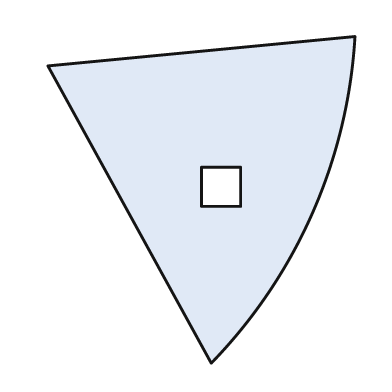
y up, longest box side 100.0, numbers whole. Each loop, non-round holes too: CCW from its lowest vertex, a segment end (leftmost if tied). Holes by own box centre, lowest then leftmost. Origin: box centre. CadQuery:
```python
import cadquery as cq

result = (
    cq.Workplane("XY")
    .moveTo(3.0, -50.0)
    .threePointArc((34.0, -4.0), (47.0, 50.0))
    .lineTo(-47.0, 41.0)
    .close()
    .moveTo(0.0, -2.0)
    .lineTo(12.0, -2.0)
    .lineTo(12.0, 10.0)
    .lineTo(0.0, 10.0)
    .close()
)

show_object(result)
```